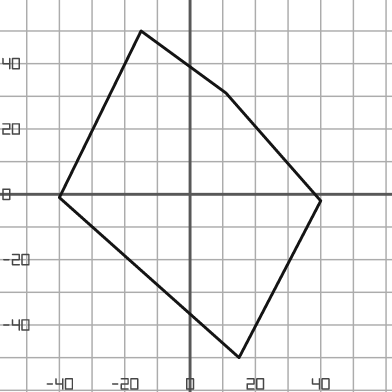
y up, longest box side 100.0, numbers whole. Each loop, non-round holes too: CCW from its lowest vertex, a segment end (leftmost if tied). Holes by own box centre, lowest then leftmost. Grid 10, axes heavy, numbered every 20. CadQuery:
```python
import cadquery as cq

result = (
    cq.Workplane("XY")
    .moveTo(15.0, -50.0)
    .lineTo(40.0, -2.0)
    .lineTo(11.0, 31.0)
    .lineTo(-15.0, 50.0)
    .lineTo(-40.0, -1.0)
    .close()
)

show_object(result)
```